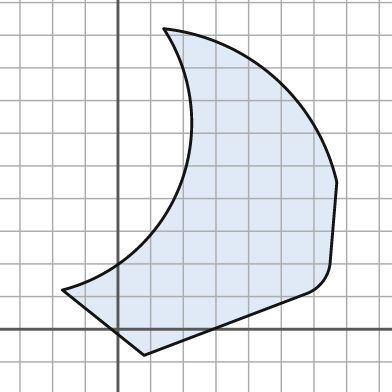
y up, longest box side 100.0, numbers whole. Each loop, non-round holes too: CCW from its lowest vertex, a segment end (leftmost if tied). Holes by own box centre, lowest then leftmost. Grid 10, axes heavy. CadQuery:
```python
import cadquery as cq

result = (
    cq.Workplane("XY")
    .moveTo(8.0, -8.0)
    .lineTo(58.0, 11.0)
    .threePointArc((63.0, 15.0), (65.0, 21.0))
    .lineTo(67.0, 45.0)
    .threePointArc((48.0, 77.0), (14.0, 92.0))
    .threePointArc((19.0, 44.0), (-17.0, 12.0))
    .close()
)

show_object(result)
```